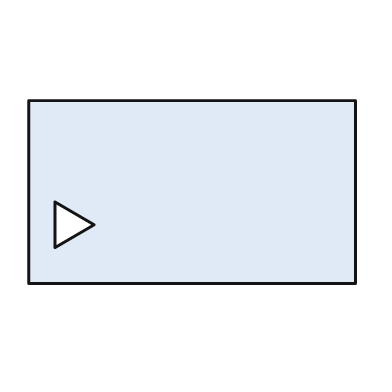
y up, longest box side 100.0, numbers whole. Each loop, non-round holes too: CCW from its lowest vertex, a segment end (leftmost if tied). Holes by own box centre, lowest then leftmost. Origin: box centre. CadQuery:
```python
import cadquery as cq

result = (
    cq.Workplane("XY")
    .moveTo(-50.0, -28.0)
    .lineTo(50.0, -28.0)
    .lineTo(50.0, 28.0)
    .lineTo(-50.0, 28.0)
    .close()
    .moveTo(-42.0, -17.0)
    .lineTo(-30.0, -10.0)
    .lineTo(-42.0, -3.0)
    .close()
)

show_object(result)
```